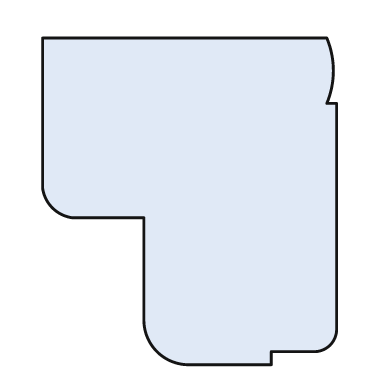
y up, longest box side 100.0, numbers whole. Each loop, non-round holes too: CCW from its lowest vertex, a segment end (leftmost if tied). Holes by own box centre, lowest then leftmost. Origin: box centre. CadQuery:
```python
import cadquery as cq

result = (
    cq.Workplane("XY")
    .moveTo(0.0, -50.0)
    .lineTo(25.0, -50.0)
    .lineTo(25.0, -46.0)
    .lineTo(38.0, -46.0)
    .threePointArc((43.0, -44.0), (45.0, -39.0))
    .lineTo(45.0, 30.0)
    .lineTo(42.0, 30.0)
    .threePointArc((44.0, 40.0), (42.0, 50.0))
    .lineTo(-45.0, 50.0)
    .lineTo(-45.0, 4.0)
    .threePointArc((-42.0, -2.0), (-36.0, -5.0))
    .lineTo(-14.0, -5.0)
    .lineTo(-14.0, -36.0)
    .threePointArc((-10.0, -46.0), (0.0, -50.0))
    .close()
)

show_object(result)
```